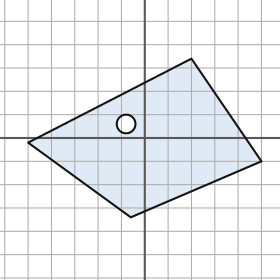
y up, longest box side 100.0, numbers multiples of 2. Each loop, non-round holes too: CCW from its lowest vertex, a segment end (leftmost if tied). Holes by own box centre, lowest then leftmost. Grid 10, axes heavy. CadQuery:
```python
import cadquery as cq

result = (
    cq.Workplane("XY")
    .moveTo(-6.0, -34.0)
    .lineTo(50.0, -10.0)
    .lineTo(20.0, 34.0)
    .lineTo(-50.0, -2.0)
    .close()
    .moveTo(-8.0, 6.0)
    .circle(4.0)
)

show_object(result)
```